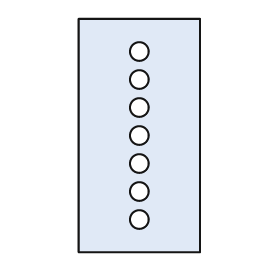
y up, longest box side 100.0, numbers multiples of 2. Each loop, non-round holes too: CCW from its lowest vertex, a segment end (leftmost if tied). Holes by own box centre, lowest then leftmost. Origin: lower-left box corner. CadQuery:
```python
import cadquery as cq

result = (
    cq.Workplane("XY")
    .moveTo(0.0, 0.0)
    .lineTo(52.0, 0.0)
    .lineTo(52.0, 100.0)
    .lineTo(0.0, 100.0)
    .close()
    .moveTo(26.0, 14.0)
    .circle(4.0)
    .moveTo(26.0, 26.0)
    .circle(4.0)
    .moveTo(26.0, 38.0)
    .circle(4.0)
    .moveTo(26.0, 50.0)
    .circle(4.0)
    .moveTo(26.0, 62.0)
    .circle(4.0)
    .moveTo(26.0, 74.0)
    .circle(4.0)
    .moveTo(26.0, 86.0)
    .circle(4.0)
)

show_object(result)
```